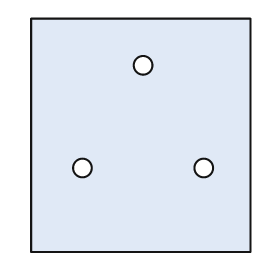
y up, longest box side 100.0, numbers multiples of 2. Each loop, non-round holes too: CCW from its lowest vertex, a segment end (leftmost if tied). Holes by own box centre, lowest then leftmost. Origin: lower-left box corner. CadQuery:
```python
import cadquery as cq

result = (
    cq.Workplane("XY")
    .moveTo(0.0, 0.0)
    .lineTo(94.0, 0.0)
    .lineTo(94.0, 100.0)
    .lineTo(0.0, 100.0)
    .close()
    .moveTo(22.0, 36.0)
    .circle(4.0)
    .moveTo(74.0, 36.0)
    .circle(4.0)
    .moveTo(48.0, 80.0)
    .circle(4.0)
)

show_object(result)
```